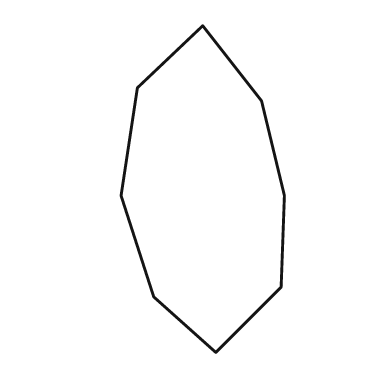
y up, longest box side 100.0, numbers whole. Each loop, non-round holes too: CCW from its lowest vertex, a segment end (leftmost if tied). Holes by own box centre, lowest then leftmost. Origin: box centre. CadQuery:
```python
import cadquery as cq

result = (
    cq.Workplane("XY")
    .moveTo(4.0, -50.0)
    .lineTo(24.0, -30.0)
    .lineTo(25.0, -2.0)
    .lineTo(18.0, 27.0)
    .lineTo(0.0, 50.0)
    .lineTo(-20.0, 31.0)
    .lineTo(-25.0, -2.0)
    .lineTo(-15.0, -33.0)
    .close()
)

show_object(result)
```